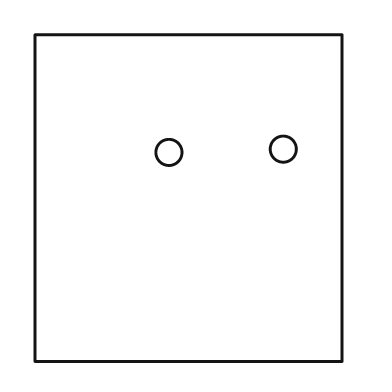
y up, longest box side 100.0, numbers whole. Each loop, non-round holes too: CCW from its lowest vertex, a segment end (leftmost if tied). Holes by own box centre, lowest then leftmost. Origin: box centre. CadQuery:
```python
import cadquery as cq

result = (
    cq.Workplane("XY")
    .moveTo(-47.0, -50.0)
    .lineTo(47.0, -50.0)
    .lineTo(47.0, 50.0)
    .lineTo(-47.0, 50.0)
    .close()
    .moveTo(-6.0, 14.0)
    .circle(4.0)
    .moveTo(29.0, 15.0)
    .circle(4.0)
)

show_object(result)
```